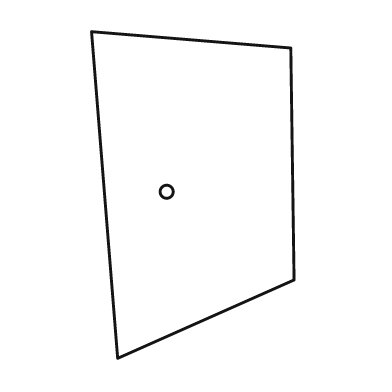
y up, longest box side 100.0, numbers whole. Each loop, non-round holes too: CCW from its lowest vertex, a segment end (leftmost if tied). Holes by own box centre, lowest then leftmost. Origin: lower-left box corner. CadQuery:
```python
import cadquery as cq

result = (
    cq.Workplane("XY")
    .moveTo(8.0, 0.0)
    .lineTo(62.0, 24.0)
    .lineTo(61.0, 95.0)
    .lineTo(0.0, 100.0)
    .close()
    .moveTo(23.0, 51.0)
    .circle(2.0)
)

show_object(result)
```